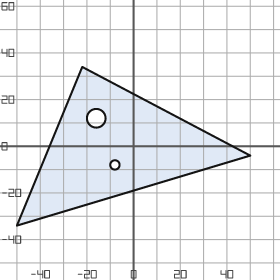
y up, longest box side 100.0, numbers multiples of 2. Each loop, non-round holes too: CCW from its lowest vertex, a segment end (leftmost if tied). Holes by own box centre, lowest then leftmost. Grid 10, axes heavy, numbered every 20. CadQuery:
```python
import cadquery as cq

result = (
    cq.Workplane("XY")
    .moveTo(-50.0, -34.0)
    .lineTo(50.0, -4.0)
    .lineTo(-22.0, 34.0)
    .close()
    .moveTo(-8.0, -8.0)
    .circle(2.0)
    .moveTo(-16.0, 12.0)
    .circle(4.0)
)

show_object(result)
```